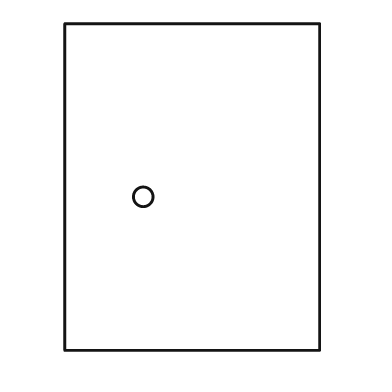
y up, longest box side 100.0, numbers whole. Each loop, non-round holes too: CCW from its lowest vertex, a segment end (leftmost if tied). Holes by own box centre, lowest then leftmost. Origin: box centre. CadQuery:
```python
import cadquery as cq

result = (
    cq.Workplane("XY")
    .moveTo(-39.0, -50.0)
    .lineTo(39.0, -50.0)
    .lineTo(39.0, 50.0)
    .lineTo(-39.0, 50.0)
    .close()
    .moveTo(-15.0, -3.0)
    .circle(3.0)
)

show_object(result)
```